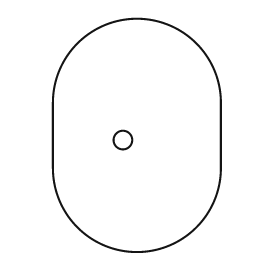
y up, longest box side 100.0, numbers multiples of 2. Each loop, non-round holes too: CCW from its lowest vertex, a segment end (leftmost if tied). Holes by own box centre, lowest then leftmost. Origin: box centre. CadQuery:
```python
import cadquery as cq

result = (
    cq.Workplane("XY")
    .moveTo(-36.0, -14.0)
    .threePointArc((0.0, -50.0), (36.0, -14.0))
    .lineTo(36.0, 14.0)
    .threePointArc((0.0, 50.0), (-36.0, 14.0))
    .close()
    .moveTo(-6.0, -2.0)
    .circle(4.0)
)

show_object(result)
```